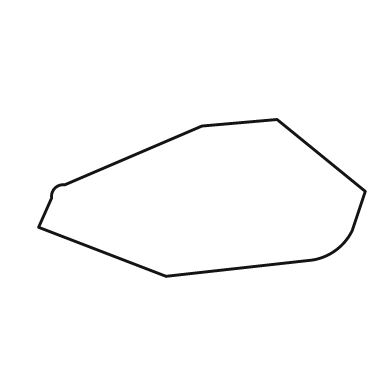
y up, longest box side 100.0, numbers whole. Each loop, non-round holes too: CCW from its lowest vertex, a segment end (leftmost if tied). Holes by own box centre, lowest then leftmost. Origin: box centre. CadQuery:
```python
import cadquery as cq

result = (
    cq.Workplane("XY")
    .moveTo(-11.0, -24.0)
    .lineTo(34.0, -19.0)
    .threePointArc((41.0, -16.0), (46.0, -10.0))
    .lineTo(50.0, 2.0)
    .lineTo(23.0, 24.0)
    .lineTo(0.0, 22.0)
    .lineTo(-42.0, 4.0)
    .threePointArc((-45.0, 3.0), (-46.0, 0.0))
    .lineTo(-50.0, -9.0)
    .close()
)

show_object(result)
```